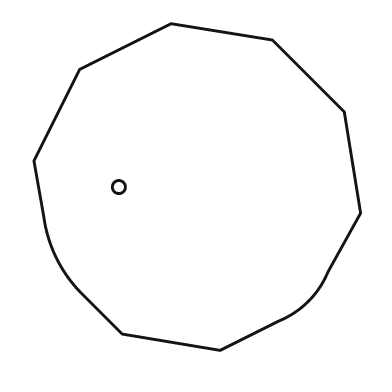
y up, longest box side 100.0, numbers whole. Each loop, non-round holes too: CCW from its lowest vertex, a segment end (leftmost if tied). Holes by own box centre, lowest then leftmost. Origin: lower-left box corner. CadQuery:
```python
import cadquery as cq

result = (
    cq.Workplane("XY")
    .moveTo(57.0, 0.0)
    .lineTo(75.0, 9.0)
    .threePointArc((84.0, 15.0), (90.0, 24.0))
    .lineTo(100.0, 42.0)
    .lineTo(95.0, 73.0)
    .lineTo(73.0, 95.0)
    .lineTo(42.0, 100.0)
    .lineTo(14.0, 86.0)
    .lineTo(0.0, 58.0)
    .lineTo(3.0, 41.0)
    .threePointArc((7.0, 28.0), (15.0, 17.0))
    .lineTo(27.0, 5.0)
    .close()
    .moveTo(26.0, 50.0)
    .circle(2.0)
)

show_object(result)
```